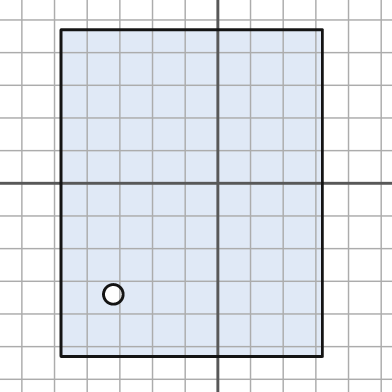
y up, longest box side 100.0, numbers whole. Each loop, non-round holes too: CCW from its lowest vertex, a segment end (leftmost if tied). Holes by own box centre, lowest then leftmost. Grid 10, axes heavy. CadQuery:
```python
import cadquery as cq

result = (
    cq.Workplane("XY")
    .moveTo(-48.0, -53.0)
    .lineTo(32.0, -53.0)
    .lineTo(32.0, 47.0)
    .lineTo(-48.0, 47.0)
    .close()
    .moveTo(-32.0, -34.0)
    .circle(3.0)
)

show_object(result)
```